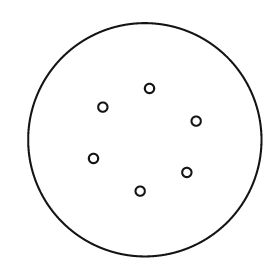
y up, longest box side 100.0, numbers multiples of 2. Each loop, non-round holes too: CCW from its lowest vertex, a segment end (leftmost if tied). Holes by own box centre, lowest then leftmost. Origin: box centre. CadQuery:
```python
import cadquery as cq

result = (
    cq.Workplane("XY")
    .moveTo(0.0, 0.0)
    .circle(50.0)
    .moveTo(-2.0, -22.0)
    .circle(2.0)
    .moveTo(18.0, -14.0)
    .circle(2.0)
    .moveTo(-22.0, -8.0)
    .circle(2.0)
    .moveTo(22.0, 8.0)
    .circle(2.0)
    .moveTo(-18.0, 14.0)
    .circle(2.0)
    .moveTo(2.0, 22.0)
    .circle(2.0)
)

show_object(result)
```